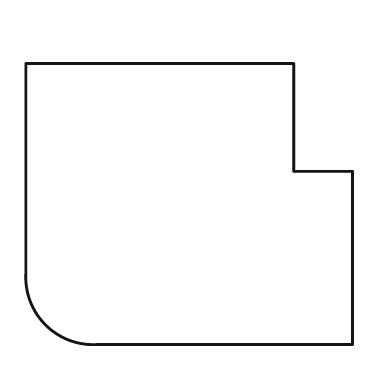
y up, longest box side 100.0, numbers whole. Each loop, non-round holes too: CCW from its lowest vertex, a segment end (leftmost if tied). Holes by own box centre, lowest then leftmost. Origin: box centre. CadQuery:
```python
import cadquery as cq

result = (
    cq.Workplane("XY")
    .moveTo(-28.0, -43.0)
    .lineTo(50.0, -43.0)
    .lineTo(50.0, 10.0)
    .lineTo(32.0, 10.0)
    .lineTo(32.0, 43.0)
    .lineTo(-50.0, 43.0)
    .lineTo(-50.0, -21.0)
    .threePointArc((-44.0, -37.0), (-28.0, -43.0))
    .close()
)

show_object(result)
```